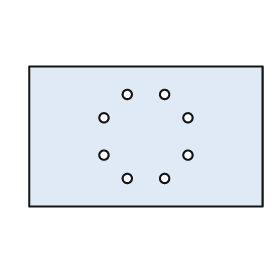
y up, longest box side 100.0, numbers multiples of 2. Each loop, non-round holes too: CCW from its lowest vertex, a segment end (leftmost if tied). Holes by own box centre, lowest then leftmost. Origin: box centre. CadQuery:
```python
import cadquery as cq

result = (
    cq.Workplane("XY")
    .moveTo(-50.0, -30.0)
    .lineTo(50.0, -30.0)
    .lineTo(50.0, 30.0)
    .lineTo(-50.0, 30.0)
    .close()
    .moveTo(-8.0, -18.0)
    .circle(2.0)
    .moveTo(8.0, -18.0)
    .circle(2.0)
    .moveTo(-18.0, -8.0)
    .circle(2.0)
    .moveTo(18.0, -8.0)
    .circle(2.0)
    .moveTo(-18.0, 8.0)
    .circle(2.0)
    .moveTo(18.0, 8.0)
    .circle(2.0)
    .moveTo(-8.0, 18.0)
    .circle(2.0)
    .moveTo(8.0, 18.0)
    .circle(2.0)
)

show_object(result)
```